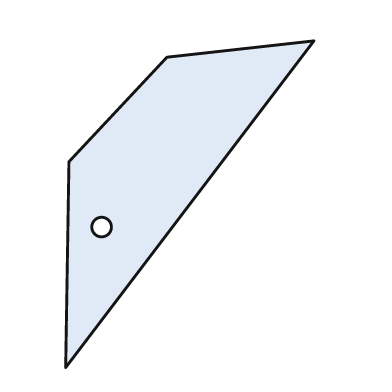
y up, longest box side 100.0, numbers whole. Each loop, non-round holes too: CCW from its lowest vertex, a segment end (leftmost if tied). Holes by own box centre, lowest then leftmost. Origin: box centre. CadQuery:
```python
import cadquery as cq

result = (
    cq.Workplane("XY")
    .moveTo(-38.0, -50.0)
    .lineTo(38.0, 50.0)
    .lineTo(-7.0, 45.0)
    .lineTo(-37.0, 13.0)
    .close()
    .moveTo(-27.0, -7.0)
    .circle(3.0)
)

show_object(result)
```